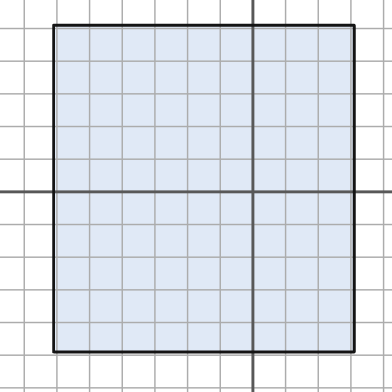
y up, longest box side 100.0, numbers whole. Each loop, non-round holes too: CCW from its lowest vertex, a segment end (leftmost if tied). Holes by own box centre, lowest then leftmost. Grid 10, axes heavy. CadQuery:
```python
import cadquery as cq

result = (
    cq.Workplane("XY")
    .moveTo(-61.0, -49.0)
    .lineTo(31.0, -49.0)
    .lineTo(31.0, 51.0)
    .lineTo(-61.0, 51.0)
    .close()
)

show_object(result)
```